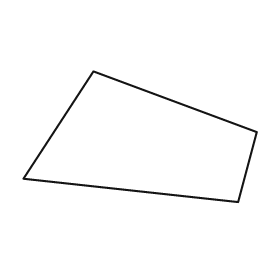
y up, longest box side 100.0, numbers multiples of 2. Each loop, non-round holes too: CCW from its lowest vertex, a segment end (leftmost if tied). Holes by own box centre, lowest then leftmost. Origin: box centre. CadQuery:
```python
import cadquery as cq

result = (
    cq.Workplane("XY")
    .moveTo(42.0, -28.0)
    .lineTo(50.0, 2.0)
    .lineTo(-20.0, 28.0)
    .lineTo(-50.0, -18.0)
    .close()
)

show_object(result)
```